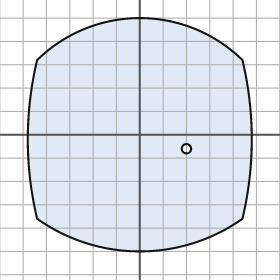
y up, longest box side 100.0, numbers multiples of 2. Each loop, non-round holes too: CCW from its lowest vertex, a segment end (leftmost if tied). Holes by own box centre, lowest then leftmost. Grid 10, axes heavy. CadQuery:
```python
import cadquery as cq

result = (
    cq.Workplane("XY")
    .moveTo(-44.0, -36.0)
    .threePointArc((0.0, -50.0), (44.0, -36.0))
    .threePointArc((48.0, -2.0), (44.0, 32.0))
    .threePointArc((0.0, 50.0), (-44.0, 32.0))
    .threePointArc((-48.0, -2.0), (-44.0, -36.0))
    .close()
    .moveTo(20.0, -6.0)
    .circle(2.0)
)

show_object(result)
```